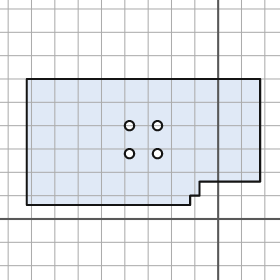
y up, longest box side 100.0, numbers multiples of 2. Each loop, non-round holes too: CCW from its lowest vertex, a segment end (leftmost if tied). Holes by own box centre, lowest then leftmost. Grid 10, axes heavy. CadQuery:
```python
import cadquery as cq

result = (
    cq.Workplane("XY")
    .moveTo(-82.0, 6.0)
    .lineTo(-12.0, 6.0)
    .lineTo(-12.0, 10.0)
    .lineTo(-8.0, 10.0)
    .lineTo(-8.0, 16.0)
    .lineTo(18.0, 16.0)
    .lineTo(18.0, 60.0)
    .lineTo(-82.0, 60.0)
    .close()
    .moveTo(-38.0, 28.0)
    .circle(2.0)
    .moveTo(-26.0, 28.0)
    .circle(2.0)
    .moveTo(-38.0, 40.0)
    .circle(2.0)
    .moveTo(-26.0, 40.0)
    .circle(2.0)
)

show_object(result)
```